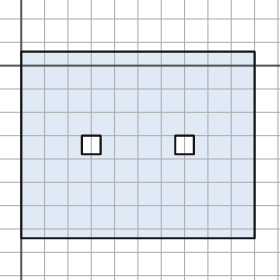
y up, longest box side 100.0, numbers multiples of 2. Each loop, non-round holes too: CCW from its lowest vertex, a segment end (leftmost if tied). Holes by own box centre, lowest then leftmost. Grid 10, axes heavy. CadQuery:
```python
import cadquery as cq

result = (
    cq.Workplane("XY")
    .moveTo(0.0, -74.0)
    .lineTo(100.0, -74.0)
    .lineTo(100.0, 6.0)
    .lineTo(0.0, 6.0)
    .close()
    .moveTo(26.0, -38.0)
    .lineTo(34.0, -38.0)
    .lineTo(34.0, -30.0)
    .lineTo(26.0, -30.0)
    .close()
    .moveTo(66.0, -38.0)
    .lineTo(74.0, -38.0)
    .lineTo(74.0, -30.0)
    .lineTo(66.0, -30.0)
    .close()
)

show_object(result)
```